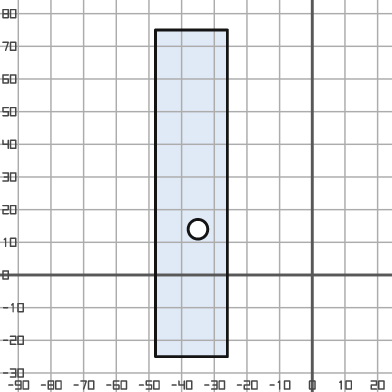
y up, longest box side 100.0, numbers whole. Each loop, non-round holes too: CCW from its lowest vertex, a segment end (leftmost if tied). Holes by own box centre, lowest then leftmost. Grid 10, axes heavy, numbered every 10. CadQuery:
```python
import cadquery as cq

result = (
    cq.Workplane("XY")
    .moveTo(-48.0, -25.0)
    .lineTo(-26.0, -25.0)
    .lineTo(-26.0, 75.0)
    .lineTo(-48.0, 75.0)
    .close()
    .moveTo(-35.0, 14.0)
    .circle(3.0)
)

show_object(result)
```